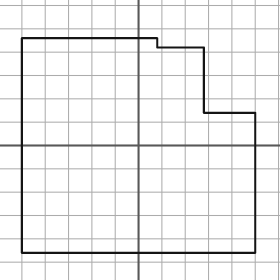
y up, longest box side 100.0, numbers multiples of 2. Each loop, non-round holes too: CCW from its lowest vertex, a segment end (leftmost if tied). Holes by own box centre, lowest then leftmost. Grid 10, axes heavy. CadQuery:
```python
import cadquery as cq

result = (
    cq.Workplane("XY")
    .moveTo(-50.0, -46.0)
    .lineTo(50.0, -46.0)
    .lineTo(50.0, 14.0)
    .lineTo(28.0, 14.0)
    .lineTo(28.0, 42.0)
    .lineTo(8.0, 42.0)
    .lineTo(8.0, 46.0)
    .lineTo(-50.0, 46.0)
    .close()
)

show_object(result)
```